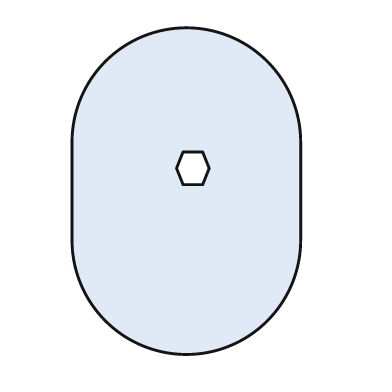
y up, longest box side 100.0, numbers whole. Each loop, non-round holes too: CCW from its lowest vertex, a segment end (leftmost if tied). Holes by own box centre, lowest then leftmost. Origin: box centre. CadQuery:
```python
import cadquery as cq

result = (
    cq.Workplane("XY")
    .moveTo(-35.0, -15.0)
    .threePointArc((0.0, -50.0), (35.0, -15.0))
    .lineTo(35.0, 15.0)
    .threePointArc((0.0, 50.0), (-35.0, 15.0))
    .close()
    .moveTo(-1.0, 2.0)
    .lineTo(5.0, 2.0)
    .lineTo(7.0, 7.0)
    .lineTo(5.0, 12.0)
    .lineTo(-1.0, 12.0)
    .lineTo(-3.0, 7.0)
    .close()
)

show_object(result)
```